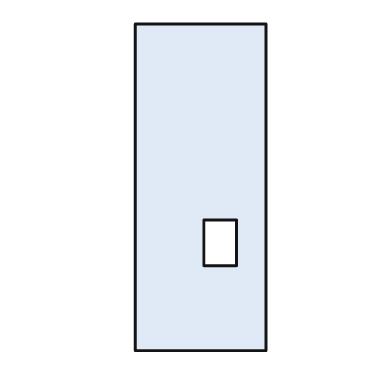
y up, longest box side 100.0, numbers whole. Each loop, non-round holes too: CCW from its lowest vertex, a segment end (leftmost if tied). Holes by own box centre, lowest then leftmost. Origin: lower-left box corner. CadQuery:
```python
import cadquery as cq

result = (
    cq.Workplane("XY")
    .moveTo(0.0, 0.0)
    .lineTo(40.0, 0.0)
    .lineTo(40.0, 100.0)
    .lineTo(0.0, 100.0)
    .close()
    .moveTo(21.0, 26.0)
    .lineTo(31.0, 26.0)
    .lineTo(31.0, 40.0)
    .lineTo(21.0, 40.0)
    .close()
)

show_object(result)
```